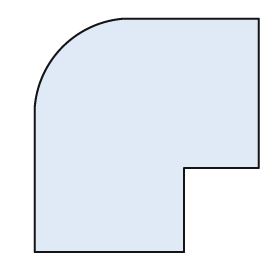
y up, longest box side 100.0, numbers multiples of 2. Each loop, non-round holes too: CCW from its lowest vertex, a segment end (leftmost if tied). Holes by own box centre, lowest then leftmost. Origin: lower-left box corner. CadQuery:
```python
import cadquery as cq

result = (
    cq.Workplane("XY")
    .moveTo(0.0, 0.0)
    .lineTo(64.0, 0.0)
    .lineTo(64.0, 36.0)
    .lineTo(96.0, 36.0)
    .lineTo(96.0, 100.0)
    .lineTo(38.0, 100.0)
    .threePointArc((12.0, 88.0), (0.0, 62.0))
    .close()
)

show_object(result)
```